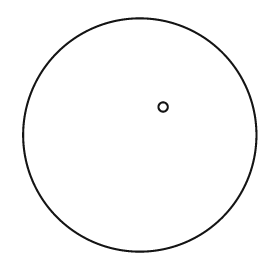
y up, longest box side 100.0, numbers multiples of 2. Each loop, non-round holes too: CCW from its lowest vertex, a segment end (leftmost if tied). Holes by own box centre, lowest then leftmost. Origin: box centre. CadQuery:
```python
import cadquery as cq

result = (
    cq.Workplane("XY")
    .moveTo(0.0, 0.0)
    .circle(50.0)
    .moveTo(10.0, 12.0)
    .circle(2.0)
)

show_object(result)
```